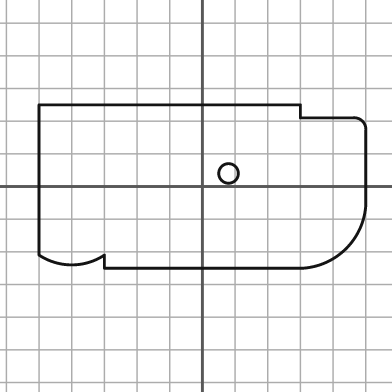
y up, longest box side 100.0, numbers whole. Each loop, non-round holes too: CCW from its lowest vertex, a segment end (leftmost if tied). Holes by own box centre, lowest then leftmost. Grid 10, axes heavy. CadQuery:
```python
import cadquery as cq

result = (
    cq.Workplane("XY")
    .moveTo(-30.0, -25.0)
    .lineTo(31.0, -25.0)
    .threePointArc((44.0, -19.0), (50.0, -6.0))
    .lineTo(50.0, 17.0)
    .threePointArc((49.0, 20.0), (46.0, 21.0))
    .lineTo(30.0, 21.0)
    .lineTo(30.0, 25.0)
    .lineTo(-50.0, 25.0)
    .lineTo(-50.0, -21.0)
    .threePointArc((-40.0, -24.0), (-30.0, -21.0))
    .close()
    .moveTo(8.0, 4.0)
    .circle(3.0)
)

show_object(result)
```